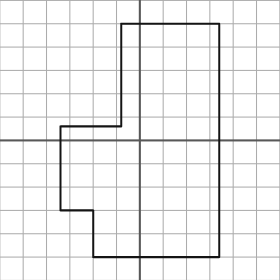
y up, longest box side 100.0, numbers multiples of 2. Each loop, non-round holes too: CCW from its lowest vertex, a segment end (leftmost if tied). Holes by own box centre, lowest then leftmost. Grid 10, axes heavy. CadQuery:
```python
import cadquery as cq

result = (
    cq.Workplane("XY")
    .moveTo(-20.0, -50.0)
    .lineTo(34.0, -50.0)
    .lineTo(34.0, 50.0)
    .lineTo(-8.0, 50.0)
    .lineTo(-8.0, 6.0)
    .lineTo(-34.0, 6.0)
    .lineTo(-34.0, -30.0)
    .lineTo(-20.0, -30.0)
    .close()
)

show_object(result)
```